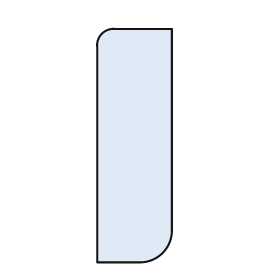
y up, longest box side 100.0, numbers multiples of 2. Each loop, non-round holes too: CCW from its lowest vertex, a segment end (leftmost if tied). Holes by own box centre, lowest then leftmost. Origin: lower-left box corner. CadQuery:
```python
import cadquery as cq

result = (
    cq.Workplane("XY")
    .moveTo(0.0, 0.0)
    .lineTo(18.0, 0.0)
    .threePointArc((28.0, 4.0), (32.0, 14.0))
    .lineTo(32.0, 100.0)
    .lineTo(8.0, 100.0)
    .threePointArc((2.0, 98.0), (0.0, 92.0))
    .close()
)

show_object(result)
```